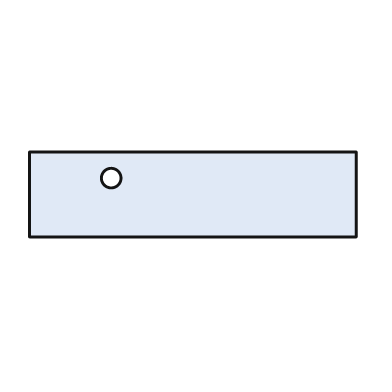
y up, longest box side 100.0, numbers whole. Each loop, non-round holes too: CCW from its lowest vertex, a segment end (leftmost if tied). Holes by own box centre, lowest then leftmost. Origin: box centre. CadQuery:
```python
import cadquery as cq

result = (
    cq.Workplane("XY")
    .moveTo(-50.0, -13.0)
    .lineTo(50.0, -13.0)
    .lineTo(50.0, 13.0)
    .lineTo(-50.0, 13.0)
    .close()
    .moveTo(-25.0, 5.0)
    .circle(3.0)
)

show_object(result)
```